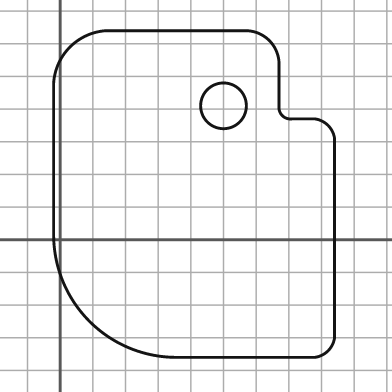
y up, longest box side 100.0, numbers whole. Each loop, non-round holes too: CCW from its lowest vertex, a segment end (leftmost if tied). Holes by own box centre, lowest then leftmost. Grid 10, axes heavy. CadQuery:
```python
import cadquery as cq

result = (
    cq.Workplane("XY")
    .moveTo(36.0, -36.0)
    .lineTo(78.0, -36.0)
    .threePointArc((82.0, -34.0), (84.0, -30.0))
    .lineTo(84.0, 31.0)
    .threePointArc((82.0, 35.0), (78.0, 37.0))
    .lineTo(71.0, 37.0)
    .threePointArc((68.0, 38.0), (67.0, 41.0))
    .lineTo(67.0, 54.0)
    .threePointArc((64.0, 61.0), (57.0, 64.0))
    .lineTo(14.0, 64.0)
    .threePointArc((3.0, 59.0), (-2.0, 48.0))
    .lineTo(-2.0, 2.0)
    .threePointArc((9.0, -25.0), (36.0, -36.0))
    .close()
    .moveTo(50.0, 41.0)
    .circle(7.0)
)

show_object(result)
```